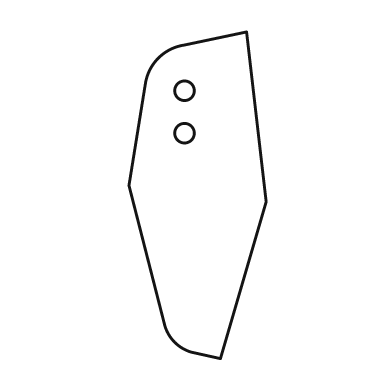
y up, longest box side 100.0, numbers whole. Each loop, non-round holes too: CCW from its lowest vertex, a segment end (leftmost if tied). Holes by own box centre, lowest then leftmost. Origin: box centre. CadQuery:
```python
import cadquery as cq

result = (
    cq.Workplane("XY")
    .moveTo(7.0, -50.0)
    .lineTo(21.0, -2.0)
    .lineTo(15.0, 50.0)
    .lineTo(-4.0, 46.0)
    .threePointArc((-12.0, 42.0), (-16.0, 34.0))
    .lineTo(-21.0, 3.0)
    .lineTo(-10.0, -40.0)
    .threePointArc((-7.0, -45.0), (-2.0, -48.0))
    .close()
    .moveTo(-4.0, 19.0)
    .circle(3.0)
    .moveTo(-4.0, 32.0)
    .circle(3.0)
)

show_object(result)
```